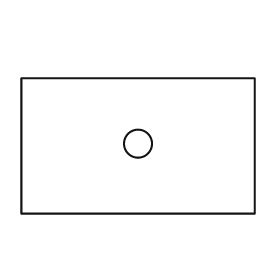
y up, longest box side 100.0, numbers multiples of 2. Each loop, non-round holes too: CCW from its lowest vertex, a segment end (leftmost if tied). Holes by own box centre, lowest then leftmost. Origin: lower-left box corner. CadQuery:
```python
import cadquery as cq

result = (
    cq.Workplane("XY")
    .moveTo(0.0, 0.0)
    .lineTo(100.0, 0.0)
    .lineTo(100.0, 58.0)
    .lineTo(0.0, 58.0)
    .close()
    .moveTo(50.0, 30.0)
    .circle(6.0)
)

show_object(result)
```